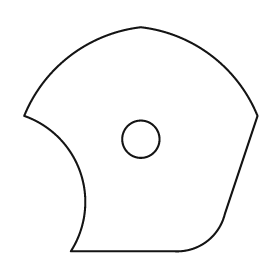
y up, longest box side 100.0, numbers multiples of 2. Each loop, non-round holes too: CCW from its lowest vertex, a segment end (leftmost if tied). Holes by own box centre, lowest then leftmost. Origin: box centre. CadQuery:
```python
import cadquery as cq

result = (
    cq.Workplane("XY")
    .moveTo(-30.0, -48.0)
    .lineTo(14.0, -48.0)
    .threePointArc((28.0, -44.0), (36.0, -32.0))
    .lineTo(50.0, 10.0)
    .threePointArc((30.0, 36.0), (0.0, 48.0))
    .threePointArc((-30.0, 36.0), (-50.0, 10.0))
    .threePointArc((-26.0, -14.0), (-30.0, -48.0))
    .close()
    .moveTo(0.0, 0.0)
    .circle(8.0)
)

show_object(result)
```